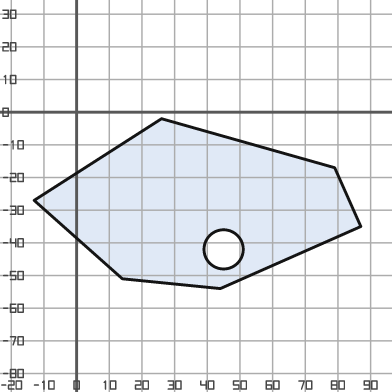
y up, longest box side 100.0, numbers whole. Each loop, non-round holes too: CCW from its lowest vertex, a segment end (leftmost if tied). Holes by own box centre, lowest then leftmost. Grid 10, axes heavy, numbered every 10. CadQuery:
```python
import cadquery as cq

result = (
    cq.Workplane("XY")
    .moveTo(44.0, -54.0)
    .lineTo(87.0, -35.0)
    .lineTo(79.0, -17.0)
    .lineTo(26.0, -2.0)
    .lineTo(-13.0, -27.0)
    .lineTo(14.0, -51.0)
    .close()
    .moveTo(45.0, -42.0)
    .circle(6.0)
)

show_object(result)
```